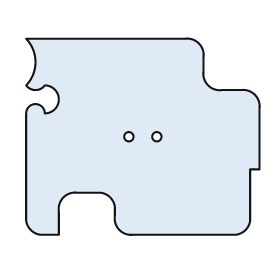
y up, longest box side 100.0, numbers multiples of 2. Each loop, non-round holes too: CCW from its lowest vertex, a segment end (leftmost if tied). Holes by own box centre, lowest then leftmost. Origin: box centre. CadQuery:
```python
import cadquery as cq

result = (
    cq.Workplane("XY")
    .moveTo(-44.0, -42.0)
    .lineTo(-36.0, -42.0)
    .lineTo(-36.0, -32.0)
    .threePointArc((-34.0, -26.0), (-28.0, -24.0))
    .lineTo(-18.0, -24.0)
    .threePointArc((-14.0, -26.0), (-12.0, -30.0))
    .lineTo(-12.0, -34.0)
    .threePointArc((-10.0, -40.0), (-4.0, -42.0))
    .lineTo(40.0, -42.0)
    .threePointArc((44.0, -40.0), (46.0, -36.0))
    .lineTo(46.0, -14.0)
    .lineTo(50.0, -14.0)
    .lineTo(50.0, 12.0)
    .threePointArc((48.0, 18.0), (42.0, 20.0))
    .lineTo(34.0, 20.0)
    .threePointArc((28.0, 22.0), (26.0, 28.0))
    .lineTo(26.0, 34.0)
    .threePointArc((24.0, 40.0), (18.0, 42.0))
    .lineTo(-50.0, 42.0)
    .threePointArc((-46.0, 32.0), (-50.0, 22.0))
    .threePointArc((-46.0, 20.0), (-42.0, 22.0))
    .threePointArc((-36.0, 16.0), (-42.0, 10.0))
    .threePointArc((-46.0, 14.0), (-50.0, 10.0))
    .lineTo(-50.0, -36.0)
    .threePointArc((-48.0, -40.0), (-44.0, -42.0))
    .close()
    .moveTo(-6.0, 0.0)
    .circle(2.0)
    .moveTo(6.0, 0.0)
    .circle(2.0)
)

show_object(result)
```